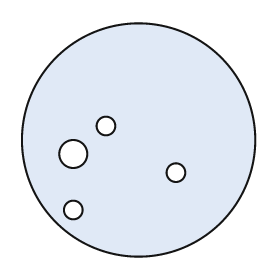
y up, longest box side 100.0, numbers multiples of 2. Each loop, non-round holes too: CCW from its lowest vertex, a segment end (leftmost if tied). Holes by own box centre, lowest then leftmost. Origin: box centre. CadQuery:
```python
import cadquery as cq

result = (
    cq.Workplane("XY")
    .moveTo(0.0, 0.0)
    .circle(50.0)
    .moveTo(-28.0, -30.0)
    .circle(4.0)
    .moveTo(16.0, -14.0)
    .circle(4.0)
    .moveTo(-28.0, -6.0)
    .circle(6.0)
    .moveTo(-14.0, 6.0)
    .circle(4.0)
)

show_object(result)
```